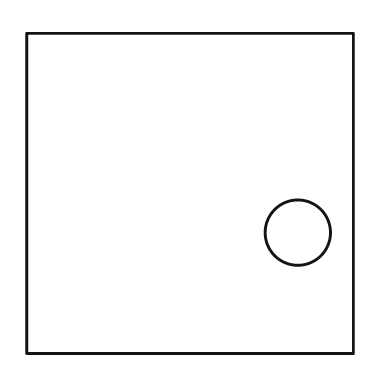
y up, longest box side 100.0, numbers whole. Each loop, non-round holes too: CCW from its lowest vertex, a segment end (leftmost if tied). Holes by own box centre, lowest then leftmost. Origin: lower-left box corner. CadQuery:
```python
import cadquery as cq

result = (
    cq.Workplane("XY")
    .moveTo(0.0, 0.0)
    .lineTo(100.0, 0.0)
    .lineTo(100.0, 98.0)
    .lineTo(0.0, 98.0)
    .close()
    .moveTo(83.0, 37.0)
    .circle(10.0)
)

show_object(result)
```